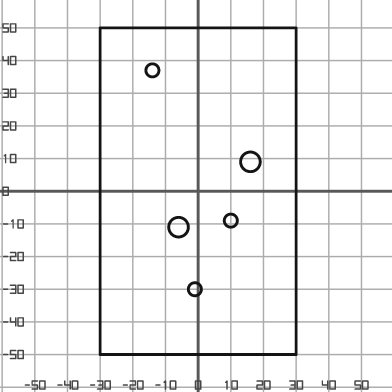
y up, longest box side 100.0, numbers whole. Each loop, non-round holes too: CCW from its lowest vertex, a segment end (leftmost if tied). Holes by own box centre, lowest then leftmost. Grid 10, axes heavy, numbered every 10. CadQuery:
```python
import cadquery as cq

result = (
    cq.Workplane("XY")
    .moveTo(-30.0, -50.0)
    .lineTo(30.0, -50.0)
    .lineTo(30.0, 50.0)
    .lineTo(-30.0, 50.0)
    .close()
    .moveTo(-1.0, -30.0)
    .circle(2.0)
    .moveTo(-6.0, -11.0)
    .circle(3.0)
    .moveTo(10.0, -9.0)
    .circle(2.0)
    .moveTo(16.0, 9.0)
    .circle(3.0)
    .moveTo(-14.0, 37.0)
    .circle(2.0)
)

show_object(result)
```